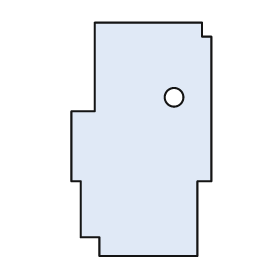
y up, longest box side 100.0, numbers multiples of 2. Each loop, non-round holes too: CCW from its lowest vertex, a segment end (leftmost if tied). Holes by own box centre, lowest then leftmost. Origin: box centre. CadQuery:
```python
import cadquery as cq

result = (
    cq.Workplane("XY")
    .moveTo(-18.0, -50.0)
    .lineTo(24.0, -50.0)
    .lineTo(24.0, -18.0)
    .lineTo(30.0, -18.0)
    .lineTo(30.0, 44.0)
    .lineTo(26.0, 44.0)
    .lineTo(26.0, 50.0)
    .lineTo(-20.0, 50.0)
    .lineTo(-20.0, 12.0)
    .lineTo(-30.0, 12.0)
    .lineTo(-30.0, -18.0)
    .lineTo(-26.0, -18.0)
    .lineTo(-26.0, -42.0)
    .lineTo(-18.0, -42.0)
    .close()
    .moveTo(14.0, 18.0)
    .circle(4.0)
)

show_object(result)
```